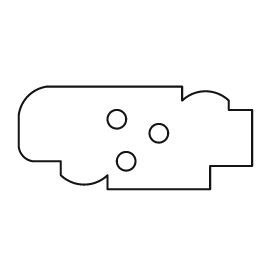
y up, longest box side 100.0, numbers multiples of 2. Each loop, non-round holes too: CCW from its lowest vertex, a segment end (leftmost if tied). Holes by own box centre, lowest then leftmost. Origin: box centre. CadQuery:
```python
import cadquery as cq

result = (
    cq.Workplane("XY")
    .moveTo(-12.0, -22.0)
    .lineTo(32.0, -22.0)
    .lineTo(32.0, -12.0)
    .lineTo(50.0, -12.0)
    .lineTo(50.0, 12.0)
    .lineTo(40.0, 12.0)
    .lineTo(40.0, 16.0)
    .threePointArc((30.0, 20.0), (20.0, 16.0))
    .lineTo(20.0, 22.0)
    .lineTo(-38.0, 22.0)
    .threePointArc((-46.0, 18.0), (-50.0, 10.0))
    .lineTo(-50.0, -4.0)
    .threePointArc((-48.0, -8.0), (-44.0, -10.0))
    .lineTo(-32.0, -10.0)
    .lineTo(-32.0, -16.0)
    .threePointArc((-22.0, -20.0), (-12.0, -16.0))
    .close()
    .moveTo(-4.0, -10.0)
    .circle(4.0)
    .moveTo(10.0, 2.0)
    .circle(4.0)
    .moveTo(-8.0, 8.0)
    .circle(4.0)
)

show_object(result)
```